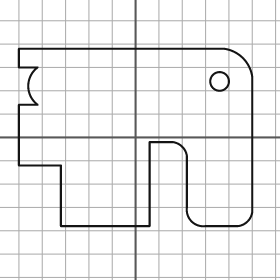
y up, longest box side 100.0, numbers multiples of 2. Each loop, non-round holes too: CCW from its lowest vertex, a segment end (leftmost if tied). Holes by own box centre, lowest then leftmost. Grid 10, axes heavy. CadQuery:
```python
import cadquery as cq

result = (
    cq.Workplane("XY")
    .moveTo(-32.0, -38.0)
    .lineTo(6.0, -38.0)
    .lineTo(6.0, -2.0)
    .lineTo(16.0, -2.0)
    .threePointArc((20.0, -4.0), (22.0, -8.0))
    .lineTo(22.0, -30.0)
    .threePointArc((24.0, -36.0), (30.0, -38.0))
    .lineTo(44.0, -38.0)
    .threePointArc((48.0, -36.0), (50.0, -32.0))
    .lineTo(50.0, 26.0)
    .threePointArc((46.0, 34.0), (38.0, 38.0))
    .lineTo(-50.0, 38.0)
    .lineTo(-50.0, 30.0)
    .lineTo(-42.0, 30.0)
    .threePointArc((-46.0, 22.0), (-42.0, 14.0))
    .lineTo(-50.0, 14.0)
    .lineTo(-50.0, -12.0)
    .lineTo(-32.0, -12.0)
    .close()
    .moveTo(36.0, 24.0)
    .circle(4.0)
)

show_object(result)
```